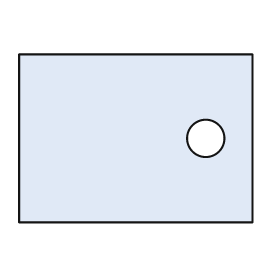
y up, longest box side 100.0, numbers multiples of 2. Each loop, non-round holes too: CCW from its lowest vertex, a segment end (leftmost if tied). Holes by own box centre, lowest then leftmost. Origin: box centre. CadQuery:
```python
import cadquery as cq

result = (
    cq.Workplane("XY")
    .moveTo(-50.0, -36.0)
    .lineTo(50.0, -36.0)
    .lineTo(50.0, 36.0)
    .lineTo(-50.0, 36.0)
    .close()
    .moveTo(30.0, 0.0)
    .circle(8.0)
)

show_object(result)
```